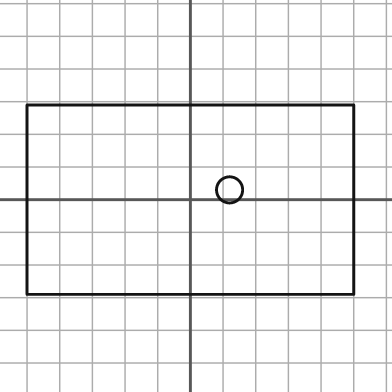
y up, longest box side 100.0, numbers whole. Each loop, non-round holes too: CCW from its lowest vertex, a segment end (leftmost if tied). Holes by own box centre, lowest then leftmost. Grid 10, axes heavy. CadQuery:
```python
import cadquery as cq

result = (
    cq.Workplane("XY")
    .moveTo(-50.0, -29.0)
    .lineTo(50.0, -29.0)
    .lineTo(50.0, 29.0)
    .lineTo(-50.0, 29.0)
    .close()
    .moveTo(12.0, 3.0)
    .circle(4.0)
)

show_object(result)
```